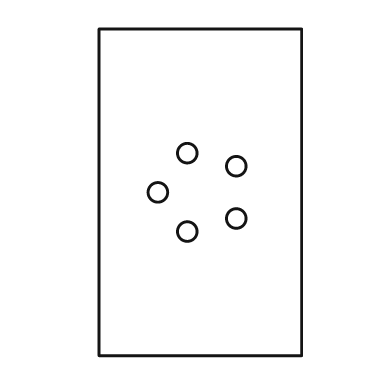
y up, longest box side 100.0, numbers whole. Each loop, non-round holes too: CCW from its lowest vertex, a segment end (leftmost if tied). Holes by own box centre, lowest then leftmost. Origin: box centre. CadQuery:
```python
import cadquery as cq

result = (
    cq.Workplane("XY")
    .moveTo(-31.0, -50.0)
    .lineTo(31.0, -50.0)
    .lineTo(31.0, 50.0)
    .lineTo(-31.0, 50.0)
    .close()
    .moveTo(-4.0, -12.0)
    .circle(3.0)
    .moveTo(11.0, -8.0)
    .circle(3.0)
    .moveTo(-13.0, 0.0)
    .circle(3.0)
    .moveTo(11.0, 8.0)
    .circle(3.0)
    .moveTo(-4.0, 12.0)
    .circle(3.0)
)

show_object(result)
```